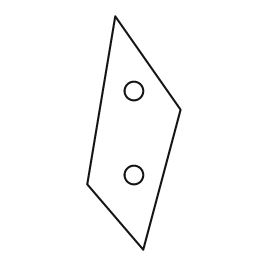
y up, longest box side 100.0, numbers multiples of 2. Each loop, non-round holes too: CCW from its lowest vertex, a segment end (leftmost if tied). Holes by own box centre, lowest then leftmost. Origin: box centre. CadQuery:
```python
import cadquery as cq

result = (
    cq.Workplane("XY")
    .moveTo(4.0, -50.0)
    .lineTo(20.0, 10.0)
    .lineTo(-8.0, 50.0)
    .lineTo(-20.0, -22.0)
    .close()
    .moveTo(0.0, -18.0)
    .circle(4.0)
    .moveTo(0.0, 18.0)
    .circle(4.0)
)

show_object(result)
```